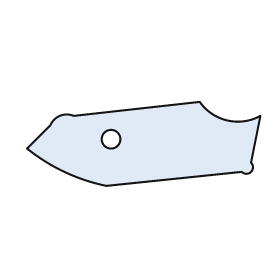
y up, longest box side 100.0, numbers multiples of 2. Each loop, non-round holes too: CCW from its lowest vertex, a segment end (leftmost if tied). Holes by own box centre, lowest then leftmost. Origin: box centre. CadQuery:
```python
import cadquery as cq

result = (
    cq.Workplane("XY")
    .moveTo(-16.0, -18.0)
    .lineTo(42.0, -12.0)
    .threePointArc((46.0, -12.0), (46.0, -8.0))
    .lineTo(50.0, 12.0)
    .threePointArc((36.0, 10.0), (24.0, 18.0))
    .lineTo(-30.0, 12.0)
    .threePointArc((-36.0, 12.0), (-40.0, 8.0))
    .lineTo(-50.0, -2.0)
    .threePointArc((-34.0, -12.0), (-16.0, -18.0))
    .close()
    .moveTo(-14.0, 2.0)
    .circle(4.0)
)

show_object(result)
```